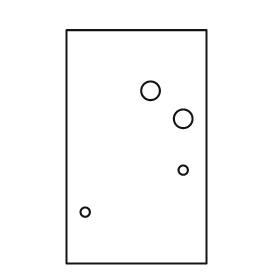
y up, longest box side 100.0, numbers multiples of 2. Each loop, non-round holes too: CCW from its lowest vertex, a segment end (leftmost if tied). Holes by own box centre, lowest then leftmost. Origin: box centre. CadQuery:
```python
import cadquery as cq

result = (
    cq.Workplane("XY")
    .moveTo(-30.0, -50.0)
    .lineTo(30.0, -50.0)
    .lineTo(30.0, 50.0)
    .lineTo(-30.0, 50.0)
    .close()
    .moveTo(-22.0, -28.0)
    .circle(2.0)
    .moveTo(20.0, -10.0)
    .circle(2.0)
    .moveTo(20.0, 12.0)
    .circle(4.0)
    .moveTo(6.0, 24.0)
    .circle(4.0)
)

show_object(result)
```